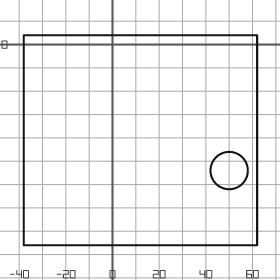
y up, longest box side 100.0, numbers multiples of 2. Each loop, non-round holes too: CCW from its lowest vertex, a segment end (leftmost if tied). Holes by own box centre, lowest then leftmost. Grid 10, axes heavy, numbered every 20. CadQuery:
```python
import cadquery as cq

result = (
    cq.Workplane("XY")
    .moveTo(-38.0, -86.0)
    .lineTo(62.0, -86.0)
    .lineTo(62.0, 4.0)
    .lineTo(-38.0, 4.0)
    .close()
    .moveTo(50.0, -54.0)
    .circle(8.0)
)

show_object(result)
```